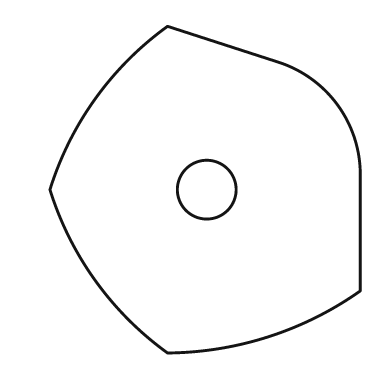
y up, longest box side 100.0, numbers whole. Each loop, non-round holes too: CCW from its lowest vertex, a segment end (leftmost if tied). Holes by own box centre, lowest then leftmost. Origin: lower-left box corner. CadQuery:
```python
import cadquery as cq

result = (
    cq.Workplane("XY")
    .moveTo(36.0, 0.0)
    .threePointArc((67.0, 5.0), (95.0, 19.0))
    .lineTo(95.0, 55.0)
    .threePointArc((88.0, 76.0), (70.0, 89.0))
    .lineTo(36.0, 100.0)
    .threePointArc((14.0, 78.0), (0.0, 50.0))
    .threePointArc((14.0, 22.0), (36.0, 0.0))
    .close()
    .moveTo(48.0, 50.0)
    .circle(9.0)
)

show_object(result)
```